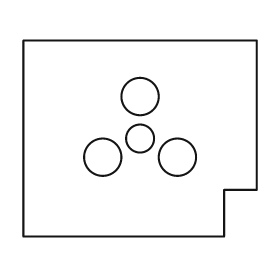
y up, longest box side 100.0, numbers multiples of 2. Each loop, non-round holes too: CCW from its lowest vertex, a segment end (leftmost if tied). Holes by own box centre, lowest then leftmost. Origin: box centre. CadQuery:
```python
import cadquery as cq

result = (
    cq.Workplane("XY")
    .moveTo(-50.0, -42.0)
    .lineTo(36.0, -42.0)
    .lineTo(36.0, -22.0)
    .lineTo(50.0, -22.0)
    .lineTo(50.0, 42.0)
    .lineTo(-50.0, 42.0)
    .close()
    .moveTo(-16.0, -8.0)
    .circle(8.0)
    .moveTo(16.0, -8.0)
    .circle(8.0)
    .moveTo(0.0, 0.0)
    .circle(6.0)
    .moveTo(0.0, 18.0)
    .circle(8.0)
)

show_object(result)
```